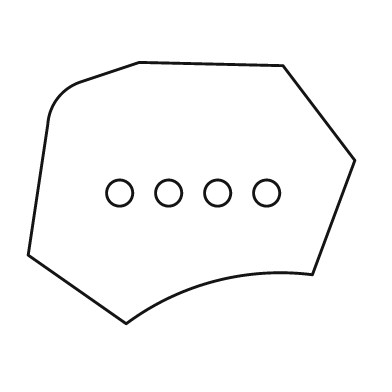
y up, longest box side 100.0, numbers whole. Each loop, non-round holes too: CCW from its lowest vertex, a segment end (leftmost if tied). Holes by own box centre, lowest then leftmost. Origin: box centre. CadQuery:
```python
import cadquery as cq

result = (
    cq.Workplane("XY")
    .moveTo(-20.0, -40.0)
    .threePointArc((7.0, -27.0), (37.0, -25.0))
    .lineTo(50.0, 10.0)
    .lineTo(28.0, 39.0)
    .lineTo(-16.0, 40.0)
    .lineTo(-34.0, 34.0)
    .threePointArc((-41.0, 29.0), (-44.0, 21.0))
    .lineTo(-50.0, -19.0)
    .close()
    .moveTo(-22.0, 0.0)
    .circle(4.0)
    .moveTo(-7.0, 0.0)
    .circle(4.0)
    .moveTo(8.0, 0.0)
    .circle(4.0)
    .moveTo(23.0, 0.0)
    .circle(4.0)
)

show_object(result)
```